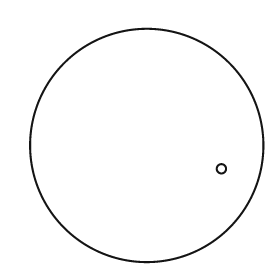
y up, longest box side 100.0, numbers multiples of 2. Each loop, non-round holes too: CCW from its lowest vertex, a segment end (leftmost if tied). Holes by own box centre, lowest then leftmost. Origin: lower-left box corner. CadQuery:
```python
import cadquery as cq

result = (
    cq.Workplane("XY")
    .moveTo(50.0, 50.0)
    .circle(50.0)
    .moveTo(82.0, 40.0)
    .circle(2.0)
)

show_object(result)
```